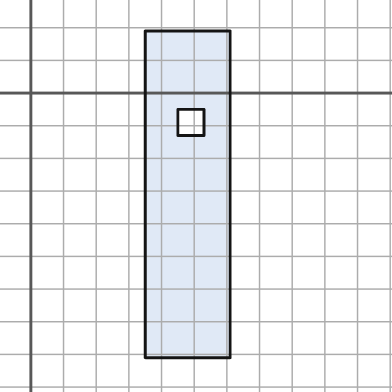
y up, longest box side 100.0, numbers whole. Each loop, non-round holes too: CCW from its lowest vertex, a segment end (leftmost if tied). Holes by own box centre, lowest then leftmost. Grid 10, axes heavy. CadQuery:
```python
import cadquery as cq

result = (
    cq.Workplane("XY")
    .moveTo(35.0, -81.0)
    .lineTo(61.0, -81.0)
    .lineTo(61.0, 19.0)
    .lineTo(35.0, 19.0)
    .close()
    .moveTo(45.0, -13.0)
    .lineTo(53.0, -13.0)
    .lineTo(53.0, -5.0)
    .lineTo(45.0, -5.0)
    .close()
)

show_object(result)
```